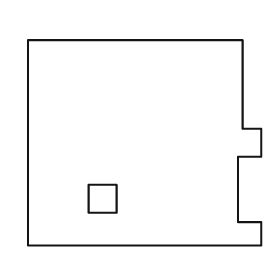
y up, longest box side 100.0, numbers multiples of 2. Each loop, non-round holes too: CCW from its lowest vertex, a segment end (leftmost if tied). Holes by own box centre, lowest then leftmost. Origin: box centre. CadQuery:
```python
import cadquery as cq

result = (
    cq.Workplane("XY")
    .moveTo(-50.0, -44.0)
    .lineTo(50.0, -44.0)
    .lineTo(50.0, -34.0)
    .lineTo(40.0, -34.0)
    .lineTo(40.0, -6.0)
    .lineTo(50.0, -6.0)
    .lineTo(50.0, 6.0)
    .lineTo(42.0, 6.0)
    .lineTo(42.0, 44.0)
    .lineTo(-50.0, 44.0)
    .close()
    .moveTo(-24.0, -30.0)
    .lineTo(-12.0, -30.0)
    .lineTo(-12.0, -18.0)
    .lineTo(-24.0, -18.0)
    .close()
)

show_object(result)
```